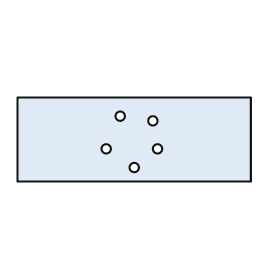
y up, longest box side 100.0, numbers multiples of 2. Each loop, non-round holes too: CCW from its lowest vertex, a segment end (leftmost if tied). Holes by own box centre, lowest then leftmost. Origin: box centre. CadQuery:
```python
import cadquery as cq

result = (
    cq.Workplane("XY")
    .moveTo(-50.0, -18.0)
    .lineTo(50.0, -18.0)
    .lineTo(50.0, 18.0)
    .lineTo(-50.0, 18.0)
    .close()
    .moveTo(0.0, -12.0)
    .circle(2.0)
    .moveTo(-12.0, -4.0)
    .circle(2.0)
    .moveTo(10.0, -4.0)
    .circle(2.0)
    .moveTo(8.0, 8.0)
    .circle(2.0)
    .moveTo(-6.0, 10.0)
    .circle(2.0)
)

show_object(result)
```